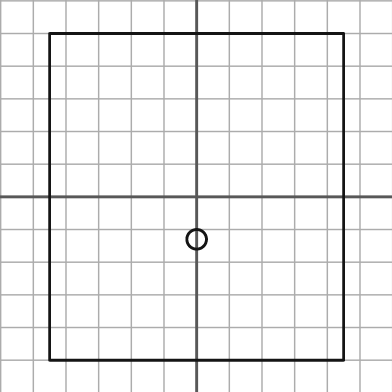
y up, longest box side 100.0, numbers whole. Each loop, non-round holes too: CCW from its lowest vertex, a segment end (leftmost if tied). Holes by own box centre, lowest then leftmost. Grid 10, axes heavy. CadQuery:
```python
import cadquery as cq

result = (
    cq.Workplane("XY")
    .moveTo(-45.0, -50.0)
    .lineTo(45.0, -50.0)
    .lineTo(45.0, 50.0)
    .lineTo(-45.0, 50.0)
    .close()
    .moveTo(0.0, -13.0)
    .circle(3.0)
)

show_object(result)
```